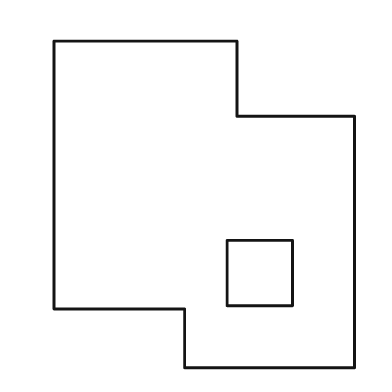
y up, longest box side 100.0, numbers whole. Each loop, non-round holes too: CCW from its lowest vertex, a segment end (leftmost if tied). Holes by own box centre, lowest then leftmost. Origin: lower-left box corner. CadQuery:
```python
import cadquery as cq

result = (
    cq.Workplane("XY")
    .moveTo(40.0, 0.0)
    .lineTo(92.0, 0.0)
    .lineTo(92.0, 77.0)
    .lineTo(56.0, 77.0)
    .lineTo(56.0, 100.0)
    .lineTo(0.0, 100.0)
    .lineTo(0.0, 18.0)
    .lineTo(40.0, 18.0)
    .close()
    .moveTo(53.0, 19.0)
    .lineTo(73.0, 19.0)
    .lineTo(73.0, 39.0)
    .lineTo(53.0, 39.0)
    .close()
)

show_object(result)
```